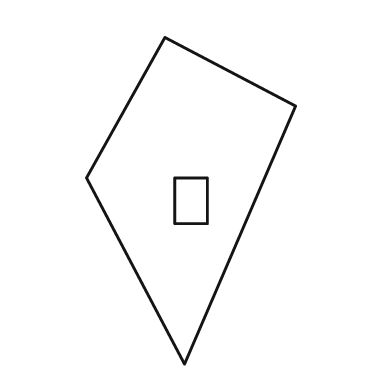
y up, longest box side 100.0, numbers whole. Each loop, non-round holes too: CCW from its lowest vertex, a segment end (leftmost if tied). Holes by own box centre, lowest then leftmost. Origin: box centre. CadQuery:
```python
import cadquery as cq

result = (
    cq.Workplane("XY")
    .moveTo(-2.0, -50.0)
    .lineTo(32.0, 29.0)
    .lineTo(-8.0, 50.0)
    .lineTo(-32.0, 7.0)
    .close()
    .moveTo(-5.0, -7.0)
    .lineTo(5.0, -7.0)
    .lineTo(5.0, 7.0)
    .lineTo(-5.0, 7.0)
    .close()
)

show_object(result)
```